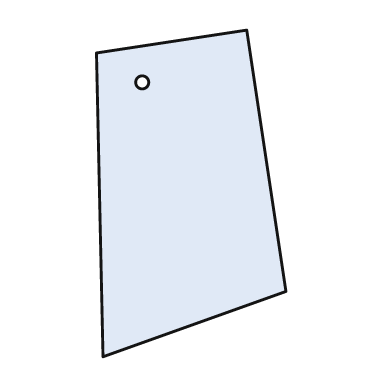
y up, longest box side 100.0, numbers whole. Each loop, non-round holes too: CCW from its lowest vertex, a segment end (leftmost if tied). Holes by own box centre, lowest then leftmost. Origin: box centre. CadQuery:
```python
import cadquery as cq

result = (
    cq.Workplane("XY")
    .moveTo(-27.0, -50.0)
    .lineTo(29.0, -30.0)
    .lineTo(17.0, 50.0)
    .lineTo(-29.0, 43.0)
    .close()
    .moveTo(-15.0, 34.0)
    .circle(2.0)
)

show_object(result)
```